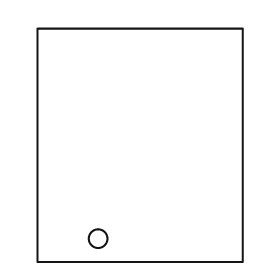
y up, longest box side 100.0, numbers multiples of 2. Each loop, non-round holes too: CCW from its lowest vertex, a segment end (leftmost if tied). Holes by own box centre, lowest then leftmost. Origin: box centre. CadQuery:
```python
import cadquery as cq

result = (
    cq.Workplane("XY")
    .moveTo(-44.0, -50.0)
    .lineTo(44.0, -50.0)
    .lineTo(44.0, 50.0)
    .lineTo(-44.0, 50.0)
    .close()
    .moveTo(-18.0, -40.0)
    .circle(4.0)
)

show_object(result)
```